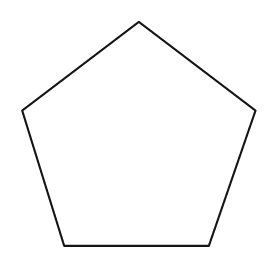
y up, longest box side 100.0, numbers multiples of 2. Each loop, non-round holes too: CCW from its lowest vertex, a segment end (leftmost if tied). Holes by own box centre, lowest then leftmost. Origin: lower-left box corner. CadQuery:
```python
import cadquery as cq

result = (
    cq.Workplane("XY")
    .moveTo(18.0, 0.0)
    .lineTo(80.0, 0.0)
    .lineTo(100.0, 58.0)
    .lineTo(50.0, 96.0)
    .lineTo(0.0, 58.0)
    .close()
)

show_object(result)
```